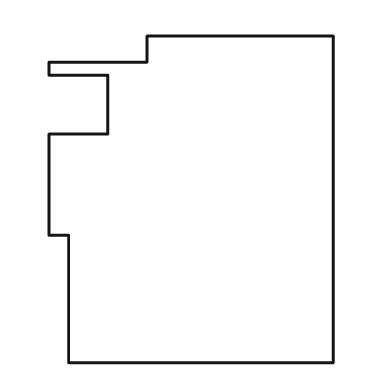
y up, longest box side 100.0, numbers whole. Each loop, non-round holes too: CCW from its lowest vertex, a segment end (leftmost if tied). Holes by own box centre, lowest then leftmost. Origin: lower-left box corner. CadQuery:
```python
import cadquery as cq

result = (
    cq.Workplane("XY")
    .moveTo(6.0, 0.0)
    .lineTo(87.0, 0.0)
    .lineTo(87.0, 100.0)
    .lineTo(30.0, 100.0)
    .lineTo(30.0, 92.0)
    .lineTo(0.0, 92.0)
    .lineTo(0.0, 88.0)
    .lineTo(18.0, 88.0)
    .lineTo(18.0, 70.0)
    .lineTo(0.0, 70.0)
    .lineTo(0.0, 39.0)
    .lineTo(6.0, 39.0)
    .close()
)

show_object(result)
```